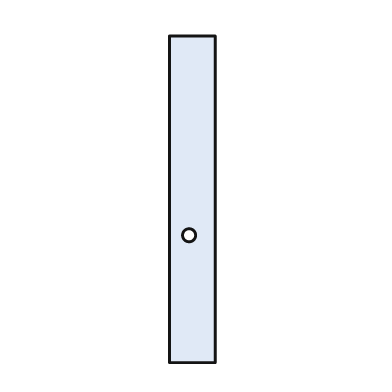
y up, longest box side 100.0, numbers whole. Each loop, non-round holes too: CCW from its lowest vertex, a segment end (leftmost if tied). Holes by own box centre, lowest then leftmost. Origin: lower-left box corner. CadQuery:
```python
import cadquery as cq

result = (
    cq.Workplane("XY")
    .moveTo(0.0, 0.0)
    .lineTo(14.0, 0.0)
    .lineTo(14.0, 100.0)
    .lineTo(0.0, 100.0)
    .close()
    .moveTo(6.0, 39.0)
    .circle(2.0)
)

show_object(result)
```